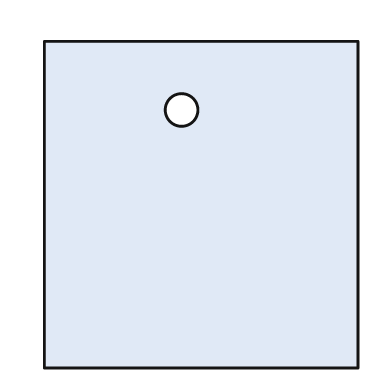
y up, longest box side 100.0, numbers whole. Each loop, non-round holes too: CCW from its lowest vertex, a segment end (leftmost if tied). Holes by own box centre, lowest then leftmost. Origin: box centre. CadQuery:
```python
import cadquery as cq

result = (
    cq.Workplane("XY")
    .moveTo(-48.0, -50.0)
    .lineTo(48.0, -50.0)
    .lineTo(48.0, 50.0)
    .lineTo(-48.0, 50.0)
    .close()
    .moveTo(-6.0, 29.0)
    .circle(5.0)
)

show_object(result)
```